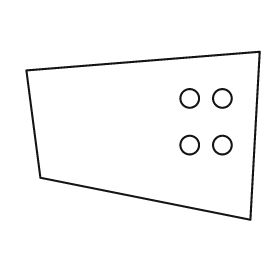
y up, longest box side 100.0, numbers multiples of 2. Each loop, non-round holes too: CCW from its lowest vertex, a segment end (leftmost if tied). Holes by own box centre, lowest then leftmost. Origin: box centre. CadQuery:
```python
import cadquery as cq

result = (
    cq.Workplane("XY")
    .moveTo(46.0, -36.0)
    .lineTo(50.0, 36.0)
    .lineTo(-50.0, 28.0)
    .lineTo(-44.0, -18.0)
    .close()
    .moveTo(20.0, -4.0)
    .circle(4.0)
    .moveTo(34.0, -4.0)
    .circle(4.0)
    .moveTo(20.0, 16.0)
    .circle(4.0)
    .moveTo(34.0, 16.0)
    .circle(4.0)
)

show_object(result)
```